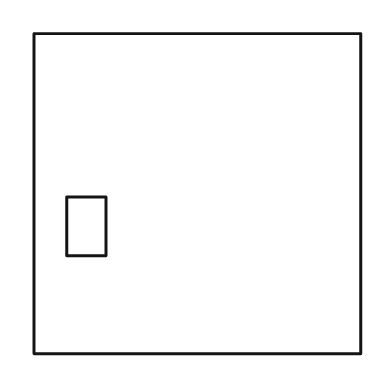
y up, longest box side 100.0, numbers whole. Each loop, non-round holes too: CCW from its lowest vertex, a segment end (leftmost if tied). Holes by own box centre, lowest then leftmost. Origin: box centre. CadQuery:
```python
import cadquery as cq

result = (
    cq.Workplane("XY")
    .moveTo(-50.0, -49.0)
    .lineTo(50.0, -49.0)
    .lineTo(50.0, 49.0)
    .lineTo(-50.0, 49.0)
    .close()
    .moveTo(-40.0, -19.0)
    .lineTo(-28.0, -19.0)
    .lineTo(-28.0, -1.0)
    .lineTo(-40.0, -1.0)
    .close()
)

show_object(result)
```